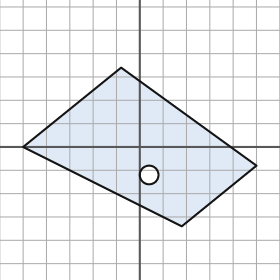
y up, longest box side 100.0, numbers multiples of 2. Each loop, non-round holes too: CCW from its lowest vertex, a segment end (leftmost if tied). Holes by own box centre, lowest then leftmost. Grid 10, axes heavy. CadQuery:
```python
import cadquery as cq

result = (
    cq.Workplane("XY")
    .moveTo(18.0, -34.0)
    .lineTo(50.0, -8.0)
    .lineTo(-8.0, 34.0)
    .lineTo(-50.0, 0.0)
    .close()
    .moveTo(4.0, -12.0)
    .circle(4.0)
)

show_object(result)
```